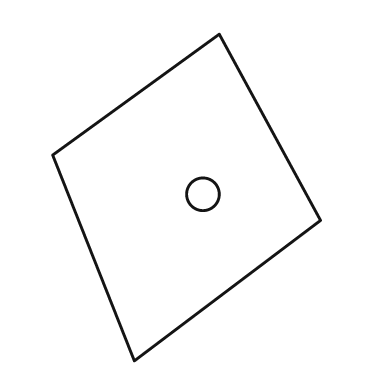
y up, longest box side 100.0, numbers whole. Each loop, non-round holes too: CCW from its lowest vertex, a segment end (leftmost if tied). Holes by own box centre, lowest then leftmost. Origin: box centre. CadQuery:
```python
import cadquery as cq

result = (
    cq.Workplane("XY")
    .moveTo(-16.0, -50.0)
    .lineTo(41.0, -7.0)
    .lineTo(10.0, 50.0)
    .lineTo(-41.0, 13.0)
    .close()
    .moveTo(5.0, 1.0)
    .circle(5.0)
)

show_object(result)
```